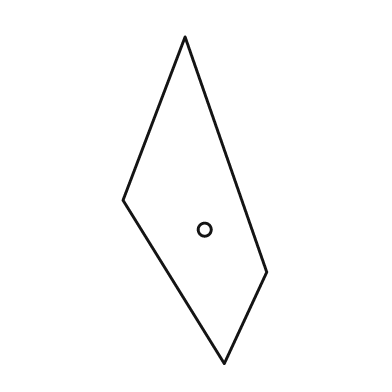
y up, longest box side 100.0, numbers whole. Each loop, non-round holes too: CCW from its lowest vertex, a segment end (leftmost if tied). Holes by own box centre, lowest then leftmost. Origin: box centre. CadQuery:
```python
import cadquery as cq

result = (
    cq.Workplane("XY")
    .moveTo(9.0, -50.0)
    .lineTo(22.0, -22.0)
    .lineTo(-3.0, 50.0)
    .lineTo(-22.0, 0.0)
    .close()
    .moveTo(3.0, -9.0)
    .circle(2.0)
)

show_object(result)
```